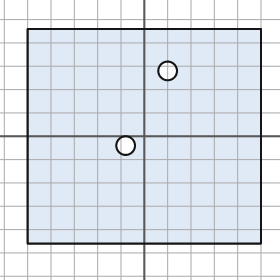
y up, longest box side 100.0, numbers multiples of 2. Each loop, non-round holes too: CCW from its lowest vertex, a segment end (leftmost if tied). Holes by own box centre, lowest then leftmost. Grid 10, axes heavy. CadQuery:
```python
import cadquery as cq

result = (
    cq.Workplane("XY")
    .moveTo(-50.0, -46.0)
    .lineTo(50.0, -46.0)
    .lineTo(50.0, 46.0)
    .lineTo(-50.0, 46.0)
    .close()
    .moveTo(-8.0, -4.0)
    .circle(4.0)
    .moveTo(10.0, 28.0)
    .circle(4.0)
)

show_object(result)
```